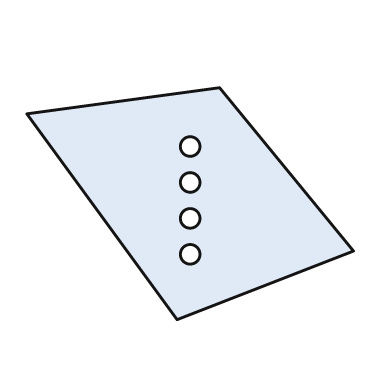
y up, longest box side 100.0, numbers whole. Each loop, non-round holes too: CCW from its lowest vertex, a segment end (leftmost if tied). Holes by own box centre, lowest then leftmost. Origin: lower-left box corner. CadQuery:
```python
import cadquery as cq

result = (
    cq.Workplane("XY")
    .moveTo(46.0, 0.0)
    .lineTo(100.0, 21.0)
    .lineTo(59.0, 71.0)
    .lineTo(0.0, 63.0)
    .close()
    .moveTo(50.0, 20.0)
    .circle(3.0)
    .moveTo(50.0, 31.0)
    .circle(3.0)
    .moveTo(50.0, 42.0)
    .circle(3.0)
    .moveTo(50.0, 53.0)
    .circle(3.0)
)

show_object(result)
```